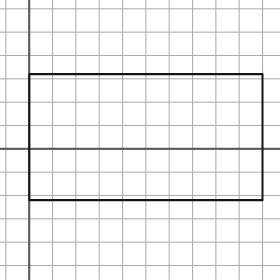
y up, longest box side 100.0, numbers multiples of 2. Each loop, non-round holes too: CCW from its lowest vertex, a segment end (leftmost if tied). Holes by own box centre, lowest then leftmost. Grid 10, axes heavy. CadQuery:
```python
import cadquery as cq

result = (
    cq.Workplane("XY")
    .moveTo(0.0, -22.0)
    .lineTo(100.0, -22.0)
    .lineTo(100.0, 32.0)
    .lineTo(0.0, 32.0)
    .close()
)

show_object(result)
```